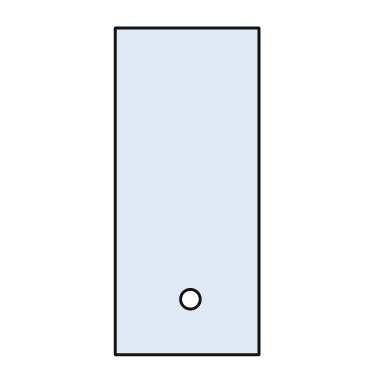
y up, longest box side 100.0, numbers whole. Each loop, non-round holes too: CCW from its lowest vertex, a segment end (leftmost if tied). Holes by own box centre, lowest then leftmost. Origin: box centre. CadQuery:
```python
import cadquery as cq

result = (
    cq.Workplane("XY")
    .moveTo(-22.0, -50.0)
    .lineTo(22.0, -50.0)
    .lineTo(22.0, 50.0)
    .lineTo(-22.0, 50.0)
    .close()
    .moveTo(1.0, -33.0)
    .circle(3.0)
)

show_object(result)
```